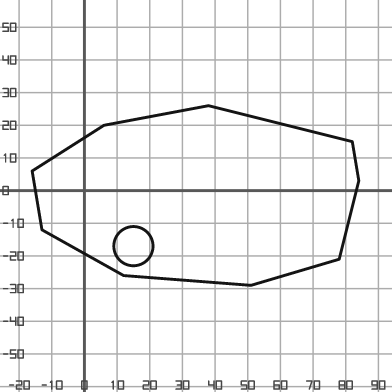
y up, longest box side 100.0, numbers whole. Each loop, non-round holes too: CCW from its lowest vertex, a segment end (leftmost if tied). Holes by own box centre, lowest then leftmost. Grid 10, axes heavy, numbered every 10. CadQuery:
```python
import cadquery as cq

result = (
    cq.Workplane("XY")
    .moveTo(51.0, -29.0)
    .lineTo(78.0, -21.0)
    .lineTo(84.0, 3.0)
    .lineTo(82.0, 15.0)
    .lineTo(38.0, 26.0)
    .lineTo(6.0, 20.0)
    .lineTo(-16.0, 6.0)
    .lineTo(-13.0, -12.0)
    .lineTo(12.0, -26.0)
    .close()
    .moveTo(15.0, -17.0)
    .circle(6.0)
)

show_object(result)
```